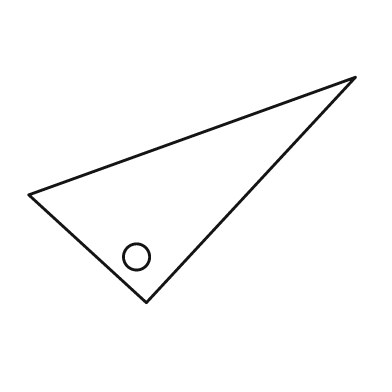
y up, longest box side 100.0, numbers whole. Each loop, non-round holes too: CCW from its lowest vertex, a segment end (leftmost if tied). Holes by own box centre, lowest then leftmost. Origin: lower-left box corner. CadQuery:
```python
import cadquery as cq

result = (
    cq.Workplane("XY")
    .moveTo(36.0, 0.0)
    .lineTo(100.0, 69.0)
    .lineTo(0.0, 33.0)
    .close()
    .moveTo(33.0, 14.0)
    .circle(4.0)
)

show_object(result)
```